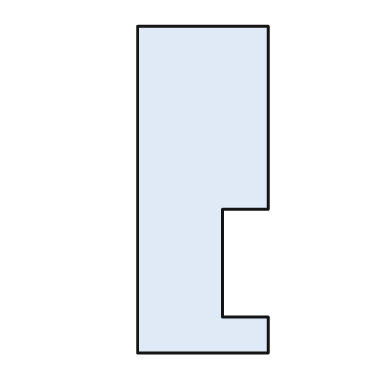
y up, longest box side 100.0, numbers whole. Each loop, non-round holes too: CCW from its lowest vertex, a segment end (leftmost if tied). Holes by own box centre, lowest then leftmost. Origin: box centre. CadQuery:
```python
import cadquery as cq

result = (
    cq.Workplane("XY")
    .moveTo(-20.0, -50.0)
    .lineTo(20.0, -50.0)
    .lineTo(20.0, -39.0)
    .lineTo(6.0, -39.0)
    .lineTo(6.0, -6.0)
    .lineTo(20.0, -6.0)
    .lineTo(20.0, 50.0)
    .lineTo(-20.0, 50.0)
    .close()
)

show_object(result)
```